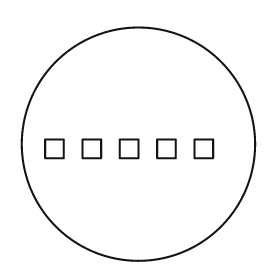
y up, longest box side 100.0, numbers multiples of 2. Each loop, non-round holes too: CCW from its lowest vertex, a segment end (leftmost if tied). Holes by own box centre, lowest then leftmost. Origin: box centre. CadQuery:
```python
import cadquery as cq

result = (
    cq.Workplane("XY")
    .moveTo(0.0, 0.0)
    .circle(50.0)
    .moveTo(-40.0, -6.0)
    .lineTo(-32.0, -6.0)
    .lineTo(-32.0, 2.0)
    .lineTo(-40.0, 2.0)
    .close()
    .moveTo(-24.0, -6.0)
    .lineTo(-16.0, -6.0)
    .lineTo(-16.0, 2.0)
    .lineTo(-24.0, 2.0)
    .close()
    .moveTo(-8.0, -6.0)
    .lineTo(0.0, -6.0)
    .lineTo(0.0, 2.0)
    .lineTo(-8.0, 2.0)
    .close()
    .moveTo(8.0, -6.0)
    .lineTo(16.0, -6.0)
    .lineTo(16.0, 2.0)
    .lineTo(8.0, 2.0)
    .close()
    .moveTo(24.0, -6.0)
    .lineTo(32.0, -6.0)
    .lineTo(32.0, 2.0)
    .lineTo(24.0, 2.0)
    .close()
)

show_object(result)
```